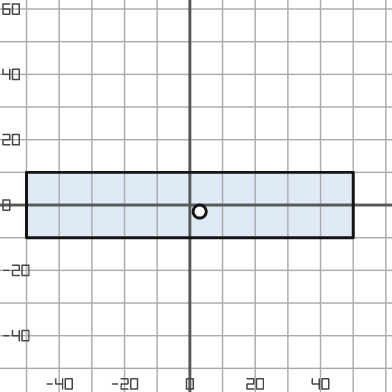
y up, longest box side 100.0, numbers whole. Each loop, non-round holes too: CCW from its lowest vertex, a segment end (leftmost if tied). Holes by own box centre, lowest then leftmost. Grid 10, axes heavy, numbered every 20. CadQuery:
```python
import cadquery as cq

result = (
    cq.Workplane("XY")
    .moveTo(-50.0, -10.0)
    .lineTo(50.0, -10.0)
    .lineTo(50.0, 10.0)
    .lineTo(-50.0, 10.0)
    .close()
    .moveTo(3.0, -2.0)
    .circle(2.0)
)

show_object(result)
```